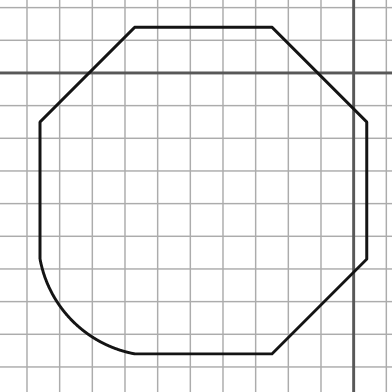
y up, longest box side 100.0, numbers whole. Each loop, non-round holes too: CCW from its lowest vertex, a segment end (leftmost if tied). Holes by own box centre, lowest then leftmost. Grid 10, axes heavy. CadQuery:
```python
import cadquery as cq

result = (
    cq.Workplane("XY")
    .moveTo(-67.0, -86.0)
    .lineTo(-25.0, -86.0)
    .lineTo(4.0, -57.0)
    .lineTo(4.0, -15.0)
    .lineTo(-25.0, 14.0)
    .lineTo(-67.0, 14.0)
    .lineTo(-96.0, -15.0)
    .lineTo(-96.0, -57.0)
    .threePointArc((-86.0, -76.0), (-67.0, -86.0))
    .close()
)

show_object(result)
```